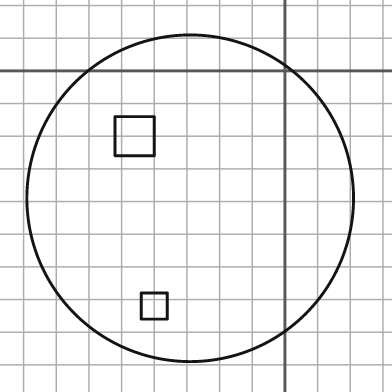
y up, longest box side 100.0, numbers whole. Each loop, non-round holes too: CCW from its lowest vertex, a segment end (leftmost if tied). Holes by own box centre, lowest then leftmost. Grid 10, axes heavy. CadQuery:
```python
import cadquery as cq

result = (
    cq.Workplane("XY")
    .moveTo(-29.0, -39.0)
    .circle(50.0)
    .moveTo(-44.0, -76.0)
    .lineTo(-36.0, -76.0)
    .lineTo(-36.0, -68.0)
    .lineTo(-44.0, -68.0)
    .close()
    .moveTo(-52.0, -26.0)
    .lineTo(-40.0, -26.0)
    .lineTo(-40.0, -14.0)
    .lineTo(-52.0, -14.0)
    .close()
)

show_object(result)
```